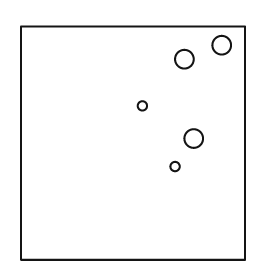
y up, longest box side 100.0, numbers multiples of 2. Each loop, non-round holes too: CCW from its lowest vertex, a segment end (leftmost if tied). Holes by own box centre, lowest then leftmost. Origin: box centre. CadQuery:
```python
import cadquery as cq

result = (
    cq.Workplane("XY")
    .moveTo(-48.0, -50.0)
    .lineTo(48.0, -50.0)
    .lineTo(48.0, 50.0)
    .lineTo(-48.0, 50.0)
    .close()
    .moveTo(18.0, -10.0)
    .circle(2.0)
    .moveTo(26.0, 2.0)
    .circle(4.0)
    .moveTo(4.0, 16.0)
    .circle(2.0)
    .moveTo(22.0, 36.0)
    .circle(4.0)
    .moveTo(38.0, 42.0)
    .circle(4.0)
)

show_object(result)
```